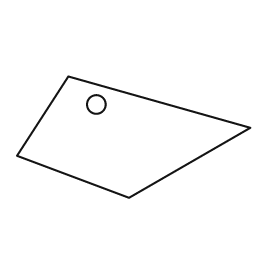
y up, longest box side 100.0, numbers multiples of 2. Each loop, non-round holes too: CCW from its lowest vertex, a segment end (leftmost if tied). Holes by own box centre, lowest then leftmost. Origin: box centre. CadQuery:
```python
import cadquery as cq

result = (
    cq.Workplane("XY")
    .moveTo(-2.0, -26.0)
    .lineTo(50.0, 4.0)
    .lineTo(-28.0, 26.0)
    .lineTo(-50.0, -8.0)
    .close()
    .moveTo(-16.0, 14.0)
    .circle(4.0)
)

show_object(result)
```